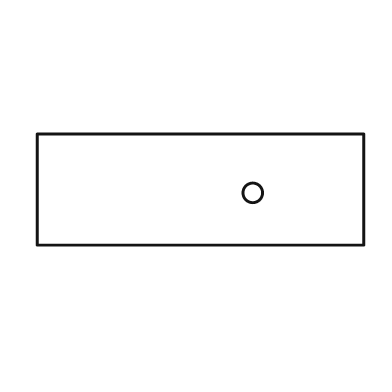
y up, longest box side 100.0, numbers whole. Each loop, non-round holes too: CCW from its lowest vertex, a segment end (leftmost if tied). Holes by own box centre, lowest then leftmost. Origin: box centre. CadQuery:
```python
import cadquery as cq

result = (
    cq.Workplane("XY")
    .moveTo(-50.0, -17.0)
    .lineTo(50.0, -17.0)
    .lineTo(50.0, 17.0)
    .lineTo(-50.0, 17.0)
    .close()
    .moveTo(16.0, -1.0)
    .circle(3.0)
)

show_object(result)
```